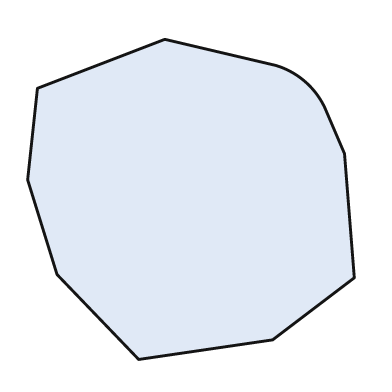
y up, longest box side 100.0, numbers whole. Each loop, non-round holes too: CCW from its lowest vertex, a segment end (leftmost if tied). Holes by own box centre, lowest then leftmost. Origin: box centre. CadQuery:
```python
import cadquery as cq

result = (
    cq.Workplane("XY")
    .moveTo(-16.0, -49.0)
    .lineTo(25.0, -43.0)
    .lineTo(50.0, -24.0)
    .lineTo(47.0, 14.0)
    .lineTo(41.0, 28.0)
    .threePointArc((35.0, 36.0), (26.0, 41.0))
    .lineTo(-8.0, 49.0)
    .lineTo(-47.0, 34.0)
    .lineTo(-50.0, 6.0)
    .lineTo(-41.0, -23.0)
    .close()
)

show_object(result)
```